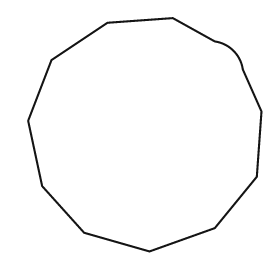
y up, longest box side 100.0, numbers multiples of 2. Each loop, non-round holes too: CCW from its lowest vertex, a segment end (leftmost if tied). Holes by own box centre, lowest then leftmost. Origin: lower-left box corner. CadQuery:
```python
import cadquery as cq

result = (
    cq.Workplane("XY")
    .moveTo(52.0, 0.0)
    .lineTo(80.0, 10.0)
    .lineTo(98.0, 32.0)
    .lineTo(100.0, 60.0)
    .lineTo(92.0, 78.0)
    .threePointArc((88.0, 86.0), (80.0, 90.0))
    .lineTo(62.0, 100.0)
    .lineTo(34.0, 98.0)
    .lineTo(10.0, 82.0)
    .lineTo(0.0, 56.0)
    .lineTo(6.0, 28.0)
    .lineTo(24.0, 8.0)
    .close()
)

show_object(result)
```